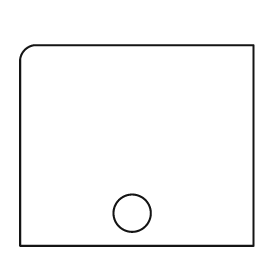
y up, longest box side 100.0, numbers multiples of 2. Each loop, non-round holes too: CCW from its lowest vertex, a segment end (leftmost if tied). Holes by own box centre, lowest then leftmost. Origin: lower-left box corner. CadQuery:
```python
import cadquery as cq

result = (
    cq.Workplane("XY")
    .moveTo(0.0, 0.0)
    .lineTo(100.0, 0.0)
    .lineTo(100.0, 86.0)
    .lineTo(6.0, 86.0)
    .threePointArc((2.0, 84.0), (0.0, 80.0))
    .close()
    .moveTo(48.0, 14.0)
    .circle(8.0)
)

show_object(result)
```